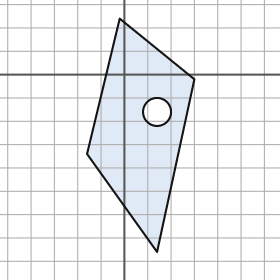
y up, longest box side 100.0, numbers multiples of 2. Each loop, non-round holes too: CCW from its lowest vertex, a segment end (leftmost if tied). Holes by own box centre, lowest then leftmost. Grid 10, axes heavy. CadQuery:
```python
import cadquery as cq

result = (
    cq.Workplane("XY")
    .moveTo(14.0, -76.0)
    .lineTo(30.0, -2.0)
    .lineTo(-2.0, 24.0)
    .lineTo(-16.0, -34.0)
    .close()
    .moveTo(14.0, -16.0)
    .circle(6.0)
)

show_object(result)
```